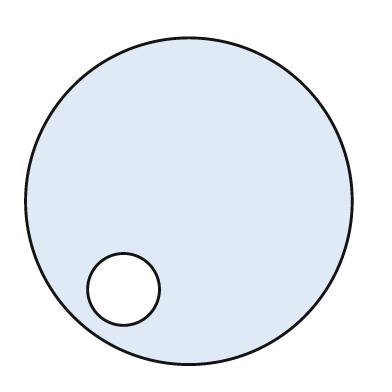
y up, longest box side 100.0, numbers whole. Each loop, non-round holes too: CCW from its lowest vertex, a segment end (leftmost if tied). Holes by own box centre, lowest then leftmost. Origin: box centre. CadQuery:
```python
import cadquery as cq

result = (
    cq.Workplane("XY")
    .moveTo(0.0, 0.0)
    .circle(50.0)
    .moveTo(-20.0, -27.0)
    .circle(11.0)
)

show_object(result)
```